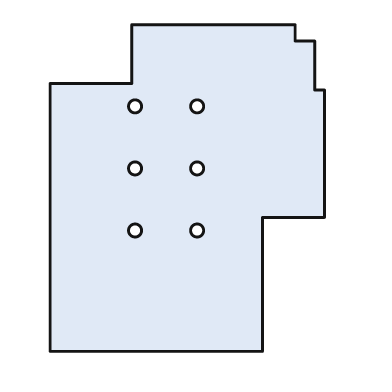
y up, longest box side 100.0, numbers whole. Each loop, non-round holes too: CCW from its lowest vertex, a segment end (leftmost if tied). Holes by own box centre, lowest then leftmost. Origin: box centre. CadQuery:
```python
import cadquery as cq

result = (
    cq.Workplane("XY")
    .moveTo(-42.0, -50.0)
    .lineTo(23.0, -50.0)
    .lineTo(23.0, -9.0)
    .lineTo(42.0, -9.0)
    .lineTo(42.0, 30.0)
    .lineTo(39.0, 30.0)
    .lineTo(39.0, 45.0)
    .lineTo(33.0, 45.0)
    .lineTo(33.0, 50.0)
    .lineTo(-17.0, 50.0)
    .lineTo(-17.0, 32.0)
    .lineTo(-42.0, 32.0)
    .close()
    .moveTo(-16.0, -13.0)
    .circle(2.0)
    .moveTo(3.0, -13.0)
    .circle(2.0)
    .moveTo(-16.0, 6.0)
    .circle(2.0)
    .moveTo(3.0, 6.0)
    .circle(2.0)
    .moveTo(-16.0, 25.0)
    .circle(2.0)
    .moveTo(3.0, 25.0)
    .circle(2.0)
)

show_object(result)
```